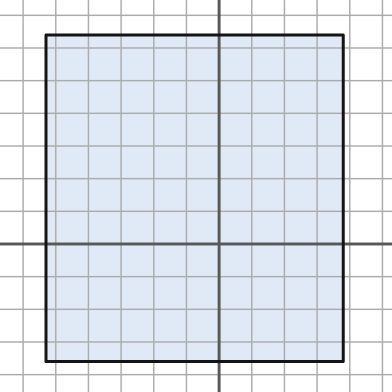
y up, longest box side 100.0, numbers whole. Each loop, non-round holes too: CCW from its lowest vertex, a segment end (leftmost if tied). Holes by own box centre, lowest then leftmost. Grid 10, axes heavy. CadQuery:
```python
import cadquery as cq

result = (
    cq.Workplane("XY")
    .moveTo(-53.0, -36.0)
    .lineTo(38.0, -36.0)
    .lineTo(38.0, 64.0)
    .lineTo(-53.0, 64.0)
    .close()
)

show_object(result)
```